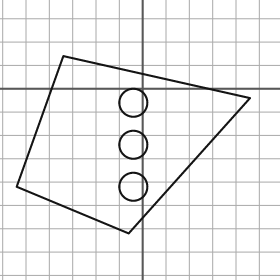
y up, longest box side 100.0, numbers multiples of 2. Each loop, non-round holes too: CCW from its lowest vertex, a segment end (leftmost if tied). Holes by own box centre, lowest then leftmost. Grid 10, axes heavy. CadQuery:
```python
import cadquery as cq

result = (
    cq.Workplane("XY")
    .moveTo(-6.0, -62.0)
    .lineTo(46.0, -4.0)
    .lineTo(-34.0, 14.0)
    .lineTo(-54.0, -42.0)
    .close()
    .moveTo(-4.0, -42.0)
    .circle(6.0)
    .moveTo(-4.0, -24.0)
    .circle(6.0)
    .moveTo(-4.0, -6.0)
    .circle(6.0)
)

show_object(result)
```